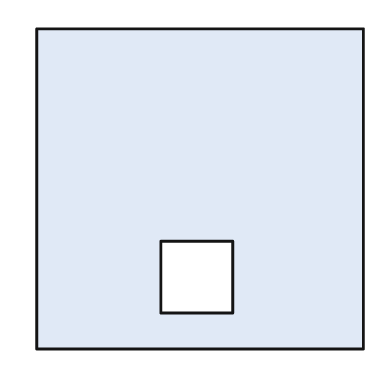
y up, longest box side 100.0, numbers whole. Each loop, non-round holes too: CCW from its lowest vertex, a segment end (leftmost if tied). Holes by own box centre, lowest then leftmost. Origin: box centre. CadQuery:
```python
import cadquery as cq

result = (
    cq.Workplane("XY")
    .moveTo(-50.0, -49.0)
    .lineTo(50.0, -49.0)
    .lineTo(50.0, 49.0)
    .lineTo(-50.0, 49.0)
    .close()
    .moveTo(-12.0, -38.0)
    .lineTo(10.0, -38.0)
    .lineTo(10.0, -16.0)
    .lineTo(-12.0, -16.0)
    .close()
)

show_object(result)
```